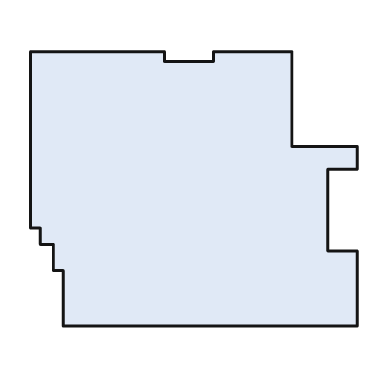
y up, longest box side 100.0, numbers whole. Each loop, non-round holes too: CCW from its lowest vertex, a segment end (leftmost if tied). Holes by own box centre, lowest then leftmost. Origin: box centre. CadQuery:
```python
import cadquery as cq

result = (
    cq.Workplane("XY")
    .moveTo(-40.0, -42.0)
    .lineTo(50.0, -42.0)
    .lineTo(50.0, -19.0)
    .lineTo(41.0, -19.0)
    .lineTo(41.0, 6.0)
    .lineTo(50.0, 6.0)
    .lineTo(50.0, 13.0)
    .lineTo(30.0, 13.0)
    .lineTo(30.0, 42.0)
    .lineTo(6.0, 42.0)
    .lineTo(6.0, 39.0)
    .lineTo(-9.0, 39.0)
    .lineTo(-9.0, 42.0)
    .lineTo(-50.0, 42.0)
    .lineTo(-50.0, -12.0)
    .lineTo(-47.0, -12.0)
    .lineTo(-47.0, -17.0)
    .lineTo(-43.0, -17.0)
    .lineTo(-43.0, -25.0)
    .lineTo(-40.0, -25.0)
    .close()
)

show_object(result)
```